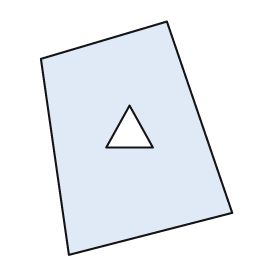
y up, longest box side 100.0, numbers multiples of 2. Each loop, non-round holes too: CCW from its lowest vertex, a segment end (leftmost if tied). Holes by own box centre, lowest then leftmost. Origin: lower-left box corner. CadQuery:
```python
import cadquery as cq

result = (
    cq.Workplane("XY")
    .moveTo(12.0, 0.0)
    .lineTo(82.0, 18.0)
    .lineTo(54.0, 100.0)
    .lineTo(0.0, 84.0)
    .close()
    .moveTo(28.0, 46.0)
    .lineTo(48.0, 46.0)
    .lineTo(38.0, 64.0)
    .close()
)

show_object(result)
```